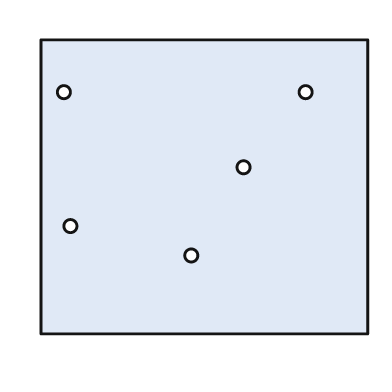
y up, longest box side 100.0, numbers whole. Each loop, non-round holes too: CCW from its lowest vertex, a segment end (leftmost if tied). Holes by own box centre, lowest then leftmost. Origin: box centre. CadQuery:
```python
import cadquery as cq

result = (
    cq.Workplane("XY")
    .moveTo(-50.0, -45.0)
    .lineTo(50.0, -45.0)
    .lineTo(50.0, 45.0)
    .lineTo(-50.0, 45.0)
    .close()
    .moveTo(-4.0, -21.0)
    .circle(2.0)
    .moveTo(-41.0, -12.0)
    .circle(2.0)
    .moveTo(12.0, 6.0)
    .circle(2.0)
    .moveTo(-43.0, 29.0)
    .circle(2.0)
    .moveTo(31.0, 29.0)
    .circle(2.0)
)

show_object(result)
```